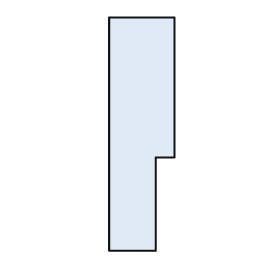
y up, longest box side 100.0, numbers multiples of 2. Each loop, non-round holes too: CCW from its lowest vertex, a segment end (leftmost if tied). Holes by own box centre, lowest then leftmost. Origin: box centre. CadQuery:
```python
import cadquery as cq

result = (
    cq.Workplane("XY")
    .moveTo(-14.0, -50.0)
    .lineTo(6.0, -50.0)
    .lineTo(6.0, -10.0)
    .lineTo(14.0, -10.0)
    .lineTo(14.0, 50.0)
    .lineTo(-14.0, 50.0)
    .close()
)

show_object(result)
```